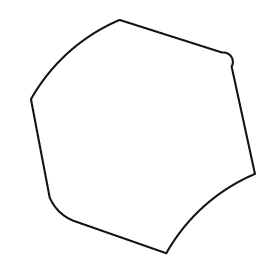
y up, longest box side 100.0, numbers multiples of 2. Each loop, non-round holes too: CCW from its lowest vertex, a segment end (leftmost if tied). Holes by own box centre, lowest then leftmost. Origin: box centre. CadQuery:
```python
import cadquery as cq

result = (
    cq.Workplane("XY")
    .moveTo(10.0, -50.0)
    .threePointArc((26.0, -30.0), (48.0, -16.0))
    .lineTo(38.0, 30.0)
    .threePointArc((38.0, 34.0), (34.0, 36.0))
    .lineTo(-10.0, 50.0)
    .threePointArc((-32.0, 36.0), (-48.0, 16.0))
    .lineTo(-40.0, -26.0)
    .threePointArc((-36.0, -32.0), (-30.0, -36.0))
    .close()
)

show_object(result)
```